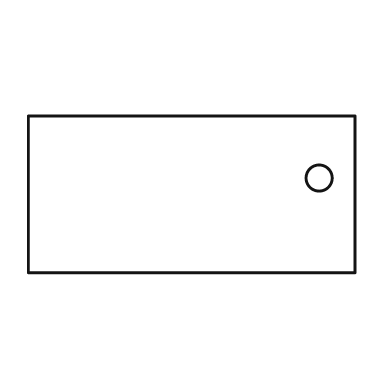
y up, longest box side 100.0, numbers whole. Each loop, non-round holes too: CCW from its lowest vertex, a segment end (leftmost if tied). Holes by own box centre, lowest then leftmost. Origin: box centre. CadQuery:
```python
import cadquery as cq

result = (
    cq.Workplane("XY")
    .moveTo(-50.0, -24.0)
    .lineTo(50.0, -24.0)
    .lineTo(50.0, 24.0)
    .lineTo(-50.0, 24.0)
    .close()
    .moveTo(39.0, 5.0)
    .circle(4.0)
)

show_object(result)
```